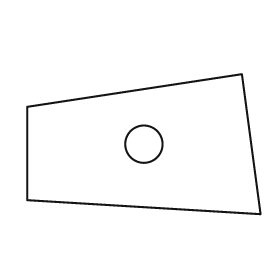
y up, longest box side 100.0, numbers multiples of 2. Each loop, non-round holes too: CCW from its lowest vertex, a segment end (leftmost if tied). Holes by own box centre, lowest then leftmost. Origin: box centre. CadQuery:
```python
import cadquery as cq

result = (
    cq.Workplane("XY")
    .moveTo(50.0, -30.0)
    .lineTo(42.0, 30.0)
    .lineTo(-50.0, 16.0)
    .lineTo(-50.0, -24.0)
    .close()
    .moveTo(0.0, 0.0)
    .circle(8.0)
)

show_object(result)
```